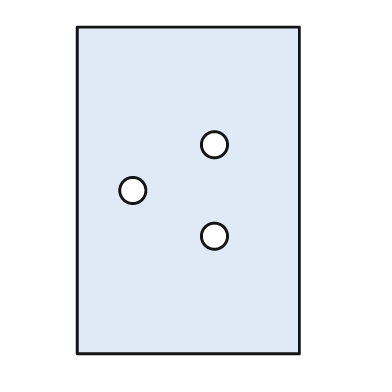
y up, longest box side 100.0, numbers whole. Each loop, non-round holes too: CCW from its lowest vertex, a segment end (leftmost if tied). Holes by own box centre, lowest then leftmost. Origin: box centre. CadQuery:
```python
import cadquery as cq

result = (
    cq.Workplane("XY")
    .moveTo(-34.0, -50.0)
    .lineTo(34.0, -50.0)
    .lineTo(34.0, 50.0)
    .lineTo(-34.0, 50.0)
    .close()
    .moveTo(8.0, -14.0)
    .circle(4.0)
    .moveTo(-17.0, 0.0)
    .circle(4.0)
    .moveTo(8.0, 14.0)
    .circle(4.0)
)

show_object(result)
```